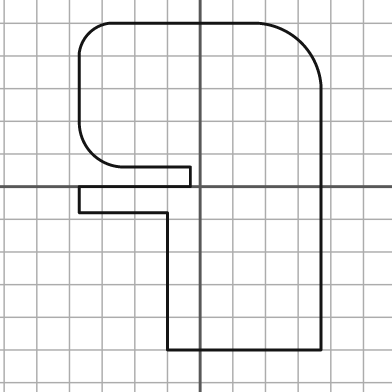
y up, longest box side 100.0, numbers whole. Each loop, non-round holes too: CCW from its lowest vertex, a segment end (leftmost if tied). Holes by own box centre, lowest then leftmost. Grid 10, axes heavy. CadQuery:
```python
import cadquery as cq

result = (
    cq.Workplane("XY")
    .moveTo(-10.0, -50.0)
    .lineTo(37.0, -50.0)
    .lineTo(37.0, 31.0)
    .threePointArc((31.0, 44.0), (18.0, 50.0))
    .lineTo(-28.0, 50.0)
    .threePointArc((-34.0, 47.0), (-37.0, 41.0))
    .lineTo(-37.0, 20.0)
    .threePointArc((-33.0, 10.0), (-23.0, 6.0))
    .lineTo(-3.0, 6.0)
    .lineTo(-3.0, 0.0)
    .lineTo(-37.0, 0.0)
    .lineTo(-37.0, -8.0)
    .lineTo(-10.0, -8.0)
    .close()
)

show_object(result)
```